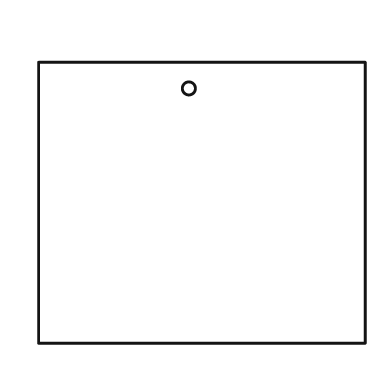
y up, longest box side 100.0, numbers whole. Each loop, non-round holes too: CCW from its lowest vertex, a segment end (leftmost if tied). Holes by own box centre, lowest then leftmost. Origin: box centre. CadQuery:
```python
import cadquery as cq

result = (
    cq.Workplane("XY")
    .moveTo(-50.0, -43.0)
    .lineTo(50.0, -43.0)
    .lineTo(50.0, 43.0)
    .lineTo(-50.0, 43.0)
    .close()
    .moveTo(-4.0, 35.0)
    .circle(2.0)
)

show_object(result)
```